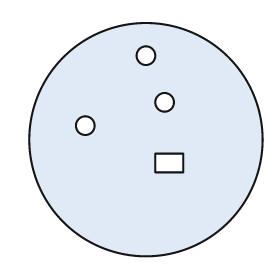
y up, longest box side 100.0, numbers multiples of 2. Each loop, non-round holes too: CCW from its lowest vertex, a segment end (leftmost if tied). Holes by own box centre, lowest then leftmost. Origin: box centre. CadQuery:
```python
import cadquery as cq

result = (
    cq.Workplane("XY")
    .moveTo(0.0, 0.0)
    .circle(50.0)
    .moveTo(4.0, -14.0)
    .lineTo(16.0, -14.0)
    .lineTo(16.0, -6.0)
    .lineTo(4.0, -6.0)
    .close()
    .moveTo(-26.0, 6.0)
    .circle(4.0)
    .moveTo(8.0, 16.0)
    .circle(4.0)
    .moveTo(0.0, 36.0)
    .circle(4.0)
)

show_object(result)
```